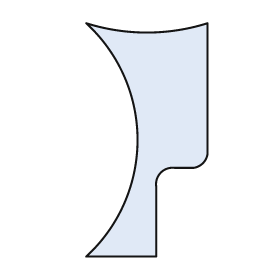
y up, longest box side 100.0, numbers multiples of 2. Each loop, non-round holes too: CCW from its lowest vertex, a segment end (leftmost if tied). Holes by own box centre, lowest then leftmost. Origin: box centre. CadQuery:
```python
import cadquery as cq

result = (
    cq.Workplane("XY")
    .moveTo(-26.0, -50.0)
    .lineTo(4.0, -50.0)
    .lineTo(4.0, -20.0)
    .threePointArc((6.0, -14.0), (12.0, -12.0))
    .lineTo(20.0, -12.0)
    .threePointArc((24.0, -10.0), (26.0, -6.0))
    .lineTo(26.0, 50.0)
    .threePointArc((0.0, 46.0), (-26.0, 50.0))
    .threePointArc((-4.0, 0.0), (-26.0, -50.0))
    .close()
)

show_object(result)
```